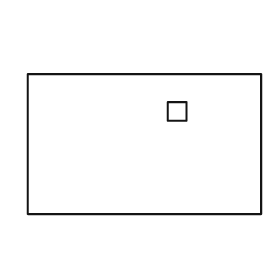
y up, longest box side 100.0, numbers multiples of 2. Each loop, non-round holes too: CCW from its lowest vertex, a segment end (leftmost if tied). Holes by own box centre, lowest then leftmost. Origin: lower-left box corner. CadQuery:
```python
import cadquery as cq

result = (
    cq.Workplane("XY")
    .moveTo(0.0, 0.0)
    .lineTo(100.0, 0.0)
    .lineTo(100.0, 60.0)
    .lineTo(0.0, 60.0)
    .close()
    .moveTo(60.0, 40.0)
    .lineTo(68.0, 40.0)
    .lineTo(68.0, 48.0)
    .lineTo(60.0, 48.0)
    .close()
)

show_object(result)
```